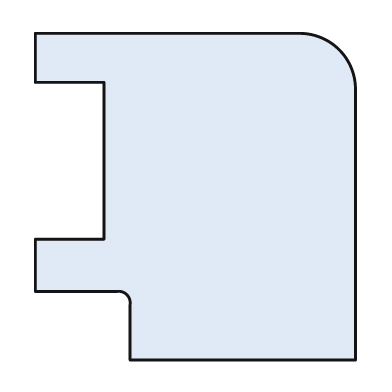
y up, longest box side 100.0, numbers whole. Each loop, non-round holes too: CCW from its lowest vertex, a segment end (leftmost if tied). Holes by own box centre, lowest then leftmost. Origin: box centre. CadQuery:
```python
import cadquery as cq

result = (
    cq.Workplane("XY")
    .moveTo(-20.0, -50.0)
    .lineTo(49.0, -50.0)
    .lineTo(49.0, 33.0)
    .threePointArc((44.0, 45.0), (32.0, 50.0))
    .lineTo(-49.0, 50.0)
    .lineTo(-49.0, 35.0)
    .lineTo(-28.0, 35.0)
    .lineTo(-28.0, -13.0)
    .lineTo(-49.0, -13.0)
    .lineTo(-49.0, -29.0)
    .lineTo(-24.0, -29.0)
    .threePointArc((-21.0, -30.0), (-20.0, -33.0))
    .close()
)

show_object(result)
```